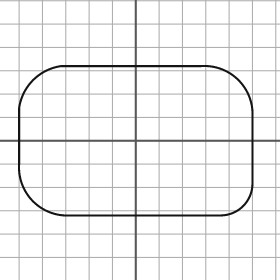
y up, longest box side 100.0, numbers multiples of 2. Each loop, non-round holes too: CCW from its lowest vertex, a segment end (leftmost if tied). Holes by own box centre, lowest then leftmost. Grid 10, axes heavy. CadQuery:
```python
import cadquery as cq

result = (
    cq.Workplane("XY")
    .moveTo(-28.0, -32.0)
    .lineTo(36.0, -32.0)
    .threePointArc((46.0, -28.0), (50.0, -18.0))
    .lineTo(50.0, 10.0)
    .threePointArc((44.0, 26.0), (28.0, 32.0))
    .lineTo(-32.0, 32.0)
    .threePointArc((-44.0, 26.0), (-50.0, 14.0))
    .lineTo(-50.0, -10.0)
    .threePointArc((-44.0, -26.0), (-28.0, -32.0))
    .close()
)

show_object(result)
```